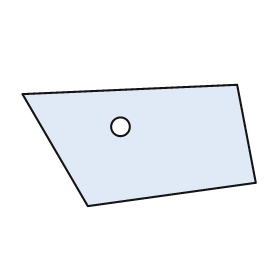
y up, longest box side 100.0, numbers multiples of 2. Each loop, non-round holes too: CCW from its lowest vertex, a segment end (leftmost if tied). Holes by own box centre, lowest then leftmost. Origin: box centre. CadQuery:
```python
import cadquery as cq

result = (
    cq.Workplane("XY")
    .moveTo(-22.0, -26.0)
    .lineTo(50.0, -16.0)
    .lineTo(42.0, 26.0)
    .lineTo(-50.0, 22.0)
    .close()
    .moveTo(-8.0, 8.0)
    .circle(4.0)
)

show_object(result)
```